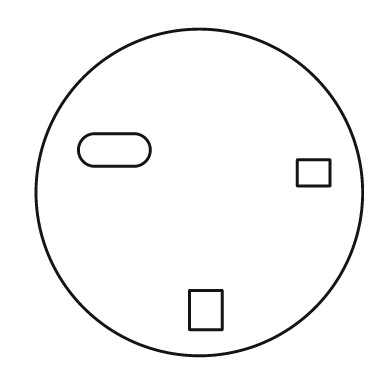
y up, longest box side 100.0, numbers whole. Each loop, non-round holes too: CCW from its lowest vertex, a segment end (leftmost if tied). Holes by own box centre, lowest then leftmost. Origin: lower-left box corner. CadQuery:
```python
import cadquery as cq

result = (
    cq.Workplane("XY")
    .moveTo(50.0, 50.0)
    .circle(50.0)
    .moveTo(47.0, 8.0)
    .lineTo(57.0, 8.0)
    .lineTo(57.0, 20.0)
    .lineTo(47.0, 20.0)
    .close()
    .moveTo(80.0, 52.0)
    .lineTo(90.0, 52.0)
    .lineTo(90.0, 60.0)
    .lineTo(80.0, 60.0)
    .close()
    .moveTo(18.0, 58.0)
    .lineTo(30.0, 58.0)
    .threePointArc((35.0, 63.0), (30.0, 68.0))
    .lineTo(18.0, 68.0)
    .threePointArc((13.0, 63.0), (18.0, 58.0))
    .close()
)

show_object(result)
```